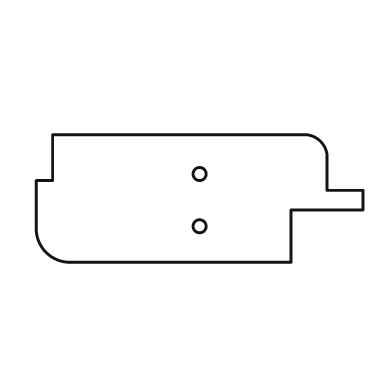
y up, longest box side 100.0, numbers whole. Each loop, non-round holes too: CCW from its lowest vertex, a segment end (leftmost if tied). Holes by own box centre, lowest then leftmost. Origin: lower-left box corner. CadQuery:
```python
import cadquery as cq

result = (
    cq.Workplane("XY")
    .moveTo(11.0, 0.0)
    .lineTo(78.0, 0.0)
    .lineTo(78.0, 16.0)
    .lineTo(100.0, 16.0)
    .lineTo(100.0, 22.0)
    .lineTo(89.0, 22.0)
    .lineTo(89.0, 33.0)
    .threePointArc((87.0, 37.0), (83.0, 39.0))
    .lineTo(5.0, 39.0)
    .lineTo(5.0, 25.0)
    .lineTo(0.0, 25.0)
    .lineTo(0.0, 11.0)
    .threePointArc((3.0, 3.0), (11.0, 0.0))
    .close()
    .moveTo(50.0, 11.0)
    .circle(2.0)
    .moveTo(50.0, 27.0)
    .circle(2.0)
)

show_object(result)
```